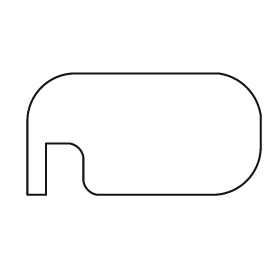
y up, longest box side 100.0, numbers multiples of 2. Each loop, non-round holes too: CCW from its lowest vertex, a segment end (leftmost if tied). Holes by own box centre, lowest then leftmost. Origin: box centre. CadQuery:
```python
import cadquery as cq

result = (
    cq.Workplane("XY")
    .moveTo(-50.0, -26.0)
    .lineTo(-42.0, -26.0)
    .lineTo(-42.0, -4.0)
    .lineTo(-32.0, -4.0)
    .threePointArc((-28.0, -6.0), (-26.0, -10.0))
    .lineTo(-26.0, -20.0)
    .threePointArc((-24.0, -24.0), (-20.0, -26.0))
    .lineTo(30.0, -26.0)
    .threePointArc((44.0, -20.0), (50.0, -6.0))
    .lineTo(50.0, 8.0)
    .threePointArc((44.0, 20.0), (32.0, 26.0))
    .lineTo(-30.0, 26.0)
    .threePointArc((-44.0, 20.0), (-50.0, 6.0))
    .close()
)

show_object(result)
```